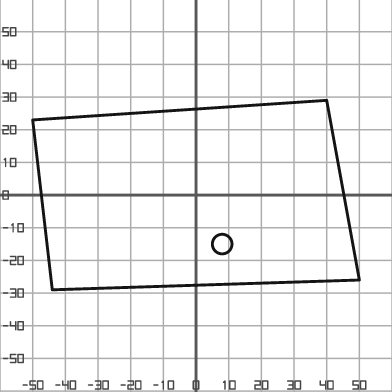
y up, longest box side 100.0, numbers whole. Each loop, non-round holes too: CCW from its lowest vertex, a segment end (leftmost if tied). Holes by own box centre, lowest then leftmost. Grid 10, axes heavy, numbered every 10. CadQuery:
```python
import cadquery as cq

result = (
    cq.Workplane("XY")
    .moveTo(-44.0, -29.0)
    .lineTo(50.0, -26.0)
    .lineTo(40.0, 29.0)
    .lineTo(-50.0, 23.0)
    .close()
    .moveTo(8.0, -15.0)
    .circle(3.0)
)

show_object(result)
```